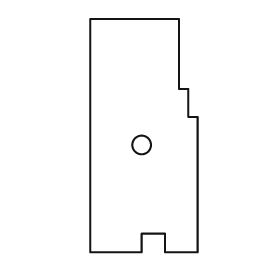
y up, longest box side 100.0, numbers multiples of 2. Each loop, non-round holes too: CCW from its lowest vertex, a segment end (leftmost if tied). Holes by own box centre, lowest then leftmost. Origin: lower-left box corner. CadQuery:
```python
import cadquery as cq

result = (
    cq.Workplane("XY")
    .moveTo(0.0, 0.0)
    .lineTo(22.0, 0.0)
    .lineTo(22.0, 8.0)
    .lineTo(32.0, 8.0)
    .lineTo(32.0, 0.0)
    .lineTo(46.0, 0.0)
    .lineTo(46.0, 58.0)
    .lineTo(42.0, 58.0)
    .lineTo(42.0, 70.0)
    .lineTo(38.0, 70.0)
    .lineTo(38.0, 100.0)
    .lineTo(0.0, 100.0)
    .close()
    .moveTo(22.0, 46.0)
    .circle(4.0)
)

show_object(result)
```